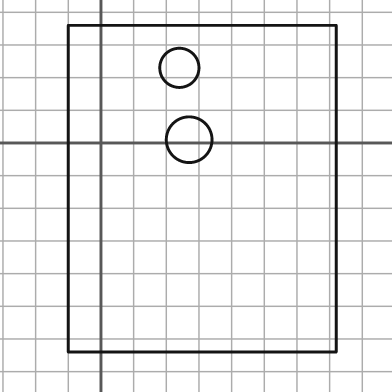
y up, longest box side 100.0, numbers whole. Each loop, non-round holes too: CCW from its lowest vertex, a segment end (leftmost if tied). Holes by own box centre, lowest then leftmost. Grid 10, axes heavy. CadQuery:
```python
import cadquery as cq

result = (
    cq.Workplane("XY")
    .moveTo(-10.0, -64.0)
    .lineTo(72.0, -64.0)
    .lineTo(72.0, 36.0)
    .lineTo(-10.0, 36.0)
    .close()
    .moveTo(27.0, 1.0)
    .circle(7.0)
    .moveTo(24.0, 23.0)
    .circle(6.0)
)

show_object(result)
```